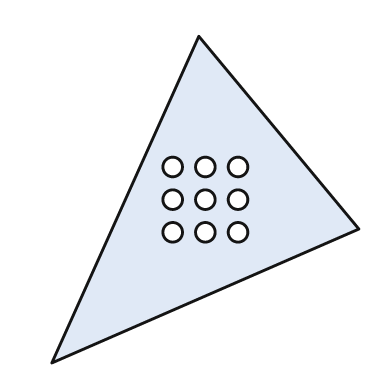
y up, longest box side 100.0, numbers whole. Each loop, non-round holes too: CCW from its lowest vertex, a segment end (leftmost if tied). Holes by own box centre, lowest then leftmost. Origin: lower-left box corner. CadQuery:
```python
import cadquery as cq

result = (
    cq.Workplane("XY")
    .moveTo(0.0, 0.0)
    .lineTo(94.0, 41.0)
    .lineTo(45.0, 100.0)
    .close()
    .moveTo(37.0, 40.0)
    .circle(3.0)
    .moveTo(47.0, 40.0)
    .circle(3.0)
    .moveTo(57.0, 40.0)
    .circle(3.0)
    .moveTo(37.0, 50.0)
    .circle(3.0)
    .moveTo(47.0, 50.0)
    .circle(3.0)
    .moveTo(57.0, 50.0)
    .circle(3.0)
    .moveTo(37.0, 60.0)
    .circle(3.0)
    .moveTo(47.0, 60.0)
    .circle(3.0)
    .moveTo(57.0, 60.0)
    .circle(3.0)
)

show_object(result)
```